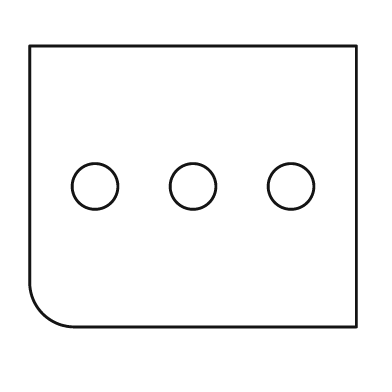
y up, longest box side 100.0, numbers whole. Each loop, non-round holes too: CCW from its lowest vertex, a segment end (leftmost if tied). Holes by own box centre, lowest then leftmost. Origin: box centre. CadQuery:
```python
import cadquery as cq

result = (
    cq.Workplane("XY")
    .moveTo(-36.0, -43.0)
    .lineTo(50.0, -43.0)
    .lineTo(50.0, 43.0)
    .lineTo(-50.0, 43.0)
    .lineTo(-50.0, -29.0)
    .threePointArc((-46.0, -39.0), (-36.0, -43.0))
    .close()
    .moveTo(-30.0, 0.0)
    .circle(7.0)
    .moveTo(0.0, 0.0)
    .circle(7.0)
    .moveTo(30.0, 0.0)
    .circle(7.0)
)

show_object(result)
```